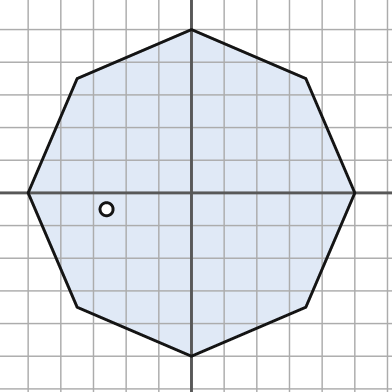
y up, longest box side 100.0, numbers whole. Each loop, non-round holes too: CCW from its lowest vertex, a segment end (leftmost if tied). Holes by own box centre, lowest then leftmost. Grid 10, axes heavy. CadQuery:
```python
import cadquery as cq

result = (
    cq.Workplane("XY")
    .moveTo(0.0, -50.0)
    .lineTo(35.0, -35.0)
    .lineTo(50.0, 0.0)
    .lineTo(35.0, 35.0)
    .lineTo(0.0, 50.0)
    .lineTo(-35.0, 35.0)
    .lineTo(-50.0, 0.0)
    .lineTo(-35.0, -35.0)
    .close()
    .moveTo(-26.0, -5.0)
    .circle(2.0)
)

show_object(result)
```